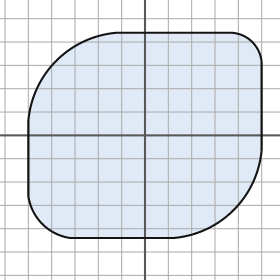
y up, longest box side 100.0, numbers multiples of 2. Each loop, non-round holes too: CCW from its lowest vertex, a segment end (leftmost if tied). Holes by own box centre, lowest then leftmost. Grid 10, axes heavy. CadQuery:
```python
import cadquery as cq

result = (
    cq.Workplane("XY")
    .moveTo(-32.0, -44.0)
    .lineTo(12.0, -44.0)
    .threePointArc((38.0, -32.0), (50.0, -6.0))
    .lineTo(50.0, 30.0)
    .threePointArc((46.0, 40.0), (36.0, 44.0))
    .lineTo(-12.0, 44.0)
    .threePointArc((-38.0, 32.0), (-50.0, 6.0))
    .lineTo(-50.0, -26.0)
    .threePointArc((-44.0, -38.0), (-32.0, -44.0))
    .close()
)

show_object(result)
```